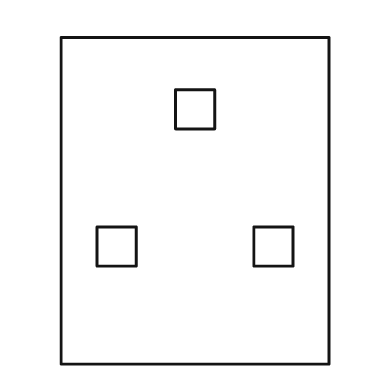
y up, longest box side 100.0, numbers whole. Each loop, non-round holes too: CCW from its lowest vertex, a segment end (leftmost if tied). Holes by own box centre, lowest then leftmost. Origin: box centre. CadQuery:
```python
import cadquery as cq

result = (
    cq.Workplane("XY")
    .moveTo(-41.0, -50.0)
    .lineTo(41.0, -50.0)
    .lineTo(41.0, 50.0)
    .lineTo(-41.0, 50.0)
    .close()
    .moveTo(-30.0, -20.0)
    .lineTo(-18.0, -20.0)
    .lineTo(-18.0, -8.0)
    .lineTo(-30.0, -8.0)
    .close()
    .moveTo(18.0, -20.0)
    .lineTo(30.0, -20.0)
    .lineTo(30.0, -8.0)
    .lineTo(18.0, -8.0)
    .close()
    .moveTo(-6.0, 22.0)
    .lineTo(6.0, 22.0)
    .lineTo(6.0, 34.0)
    .lineTo(-6.0, 34.0)
    .close()
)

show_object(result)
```